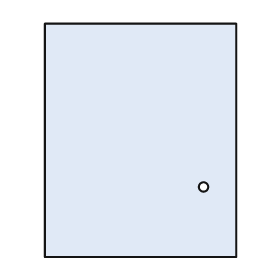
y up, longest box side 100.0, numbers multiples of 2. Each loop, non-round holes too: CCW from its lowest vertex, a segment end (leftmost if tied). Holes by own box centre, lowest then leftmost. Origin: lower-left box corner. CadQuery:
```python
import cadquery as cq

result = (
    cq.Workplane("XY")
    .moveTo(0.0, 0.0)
    .lineTo(82.0, 0.0)
    .lineTo(82.0, 100.0)
    .lineTo(0.0, 100.0)
    .close()
    .moveTo(68.0, 30.0)
    .circle(2.0)
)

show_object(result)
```